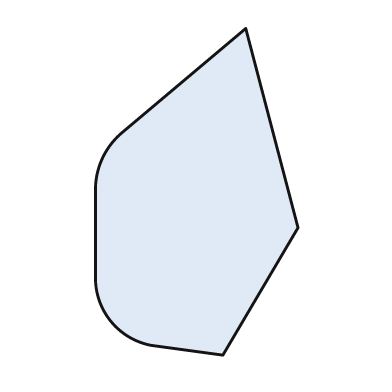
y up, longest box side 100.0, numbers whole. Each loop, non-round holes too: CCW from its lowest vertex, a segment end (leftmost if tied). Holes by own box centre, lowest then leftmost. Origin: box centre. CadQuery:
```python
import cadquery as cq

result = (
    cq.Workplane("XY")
    .moveTo(8.0, -50.0)
    .lineTo(31.0, -11.0)
    .lineTo(15.0, 50.0)
    .lineTo(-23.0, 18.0)
    .threePointArc((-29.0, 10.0), (-31.0, 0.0))
    .lineTo(-31.0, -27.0)
    .threePointArc((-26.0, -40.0), (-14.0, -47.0))
    .close()
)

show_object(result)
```